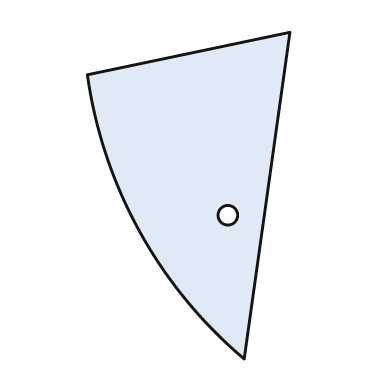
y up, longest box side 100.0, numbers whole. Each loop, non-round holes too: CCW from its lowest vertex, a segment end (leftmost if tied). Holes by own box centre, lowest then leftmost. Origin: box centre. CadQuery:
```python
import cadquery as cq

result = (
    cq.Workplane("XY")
    .moveTo(17.0, -50.0)
    .lineTo(31.0, 50.0)
    .lineTo(-31.0, 37.0)
    .threePointArc((-15.0, -11.0), (17.0, -50.0))
    .close()
    .moveTo(12.0, -6.0)
    .circle(3.0)
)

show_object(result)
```